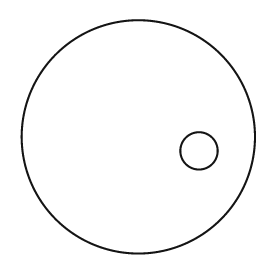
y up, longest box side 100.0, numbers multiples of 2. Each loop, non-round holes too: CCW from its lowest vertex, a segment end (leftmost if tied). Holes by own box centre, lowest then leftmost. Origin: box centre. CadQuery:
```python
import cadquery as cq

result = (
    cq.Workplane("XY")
    .moveTo(0.0, 0.0)
    .circle(50.0)
    .moveTo(26.0, -6.0)
    .circle(8.0)
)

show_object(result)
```